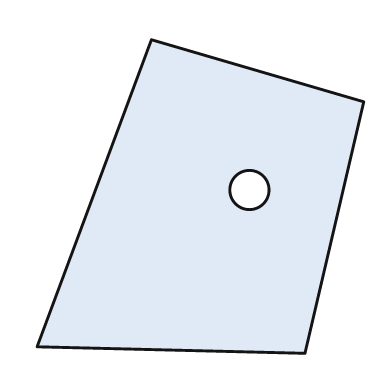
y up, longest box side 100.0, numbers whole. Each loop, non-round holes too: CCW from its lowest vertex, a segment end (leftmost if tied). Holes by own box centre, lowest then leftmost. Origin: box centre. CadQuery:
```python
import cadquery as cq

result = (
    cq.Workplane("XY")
    .moveTo(32.0, -48.0)
    .lineTo(50.0, 29.0)
    .lineTo(-15.0, 48.0)
    .lineTo(-50.0, -46.0)
    .close()
    .moveTo(15.0, 2.0)
    .circle(6.0)
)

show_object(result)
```